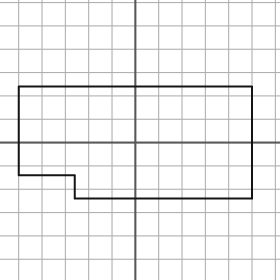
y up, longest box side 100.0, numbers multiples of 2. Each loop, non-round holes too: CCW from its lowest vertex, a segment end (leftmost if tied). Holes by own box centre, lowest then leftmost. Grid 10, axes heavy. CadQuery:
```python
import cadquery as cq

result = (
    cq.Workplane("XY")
    .moveTo(-26.0, -24.0)
    .lineTo(50.0, -24.0)
    .lineTo(50.0, 24.0)
    .lineTo(-50.0, 24.0)
    .lineTo(-50.0, -14.0)
    .lineTo(-26.0, -14.0)
    .close()
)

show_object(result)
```